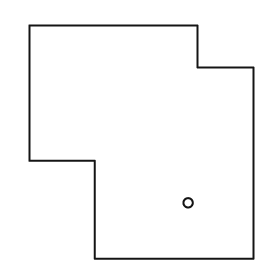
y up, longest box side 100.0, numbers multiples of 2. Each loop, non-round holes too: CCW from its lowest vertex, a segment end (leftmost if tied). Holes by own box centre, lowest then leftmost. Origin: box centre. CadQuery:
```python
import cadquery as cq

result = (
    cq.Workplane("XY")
    .moveTo(-20.0, -50.0)
    .lineTo(48.0, -50.0)
    .lineTo(48.0, 32.0)
    .lineTo(24.0, 32.0)
    .lineTo(24.0, 50.0)
    .lineTo(-48.0, 50.0)
    .lineTo(-48.0, -8.0)
    .lineTo(-20.0, -8.0)
    .close()
    .moveTo(20.0, -26.0)
    .circle(2.0)
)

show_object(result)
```